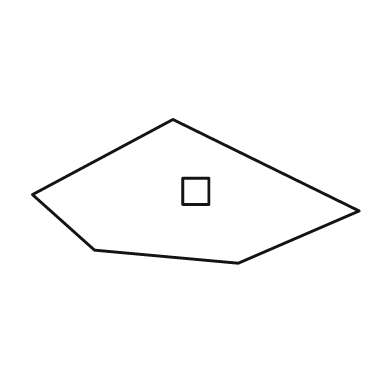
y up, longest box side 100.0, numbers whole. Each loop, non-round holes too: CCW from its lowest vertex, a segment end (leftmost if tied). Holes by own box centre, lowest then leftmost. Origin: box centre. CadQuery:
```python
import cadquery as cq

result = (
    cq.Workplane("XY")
    .moveTo(13.0, -22.0)
    .lineTo(50.0, -6.0)
    .lineTo(-7.0, 22.0)
    .lineTo(-50.0, -1.0)
    .lineTo(-31.0, -18.0)
    .close()
    .moveTo(-4.0, -4.0)
    .lineTo(4.0, -4.0)
    .lineTo(4.0, 4.0)
    .lineTo(-4.0, 4.0)
    .close()
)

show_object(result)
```